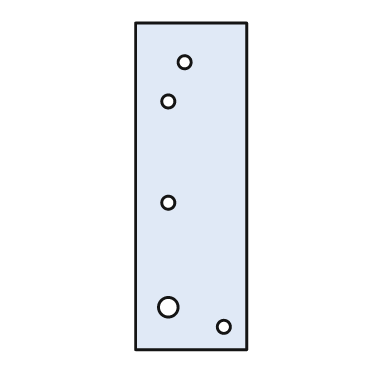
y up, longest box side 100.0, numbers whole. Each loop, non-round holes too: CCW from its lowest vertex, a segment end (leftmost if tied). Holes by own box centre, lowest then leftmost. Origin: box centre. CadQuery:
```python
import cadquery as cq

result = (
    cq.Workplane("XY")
    .moveTo(-17.0, -50.0)
    .lineTo(17.0, -50.0)
    .lineTo(17.0, 50.0)
    .lineTo(-17.0, 50.0)
    .close()
    .moveTo(10.0, -43.0)
    .circle(2.0)
    .moveTo(-7.0, -37.0)
    .circle(3.0)
    .moveTo(-7.0, -5.0)
    .circle(2.0)
    .moveTo(-7.0, 26.0)
    .circle(2.0)
    .moveTo(-2.0, 38.0)
    .circle(2.0)
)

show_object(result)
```